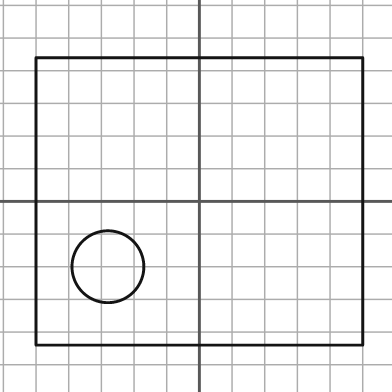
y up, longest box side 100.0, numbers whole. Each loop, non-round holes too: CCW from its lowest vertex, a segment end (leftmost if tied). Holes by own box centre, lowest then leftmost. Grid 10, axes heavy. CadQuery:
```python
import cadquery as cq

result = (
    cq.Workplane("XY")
    .moveTo(-50.0, -44.0)
    .lineTo(50.0, -44.0)
    .lineTo(50.0, 44.0)
    .lineTo(-50.0, 44.0)
    .close()
    .moveTo(-28.0, -20.0)
    .circle(11.0)
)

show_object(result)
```